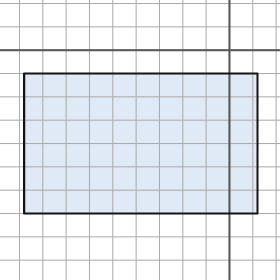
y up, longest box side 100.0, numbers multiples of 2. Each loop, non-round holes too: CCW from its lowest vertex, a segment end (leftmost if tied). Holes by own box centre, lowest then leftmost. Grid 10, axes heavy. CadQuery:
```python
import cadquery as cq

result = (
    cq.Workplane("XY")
    .moveTo(-88.0, -70.0)
    .lineTo(12.0, -70.0)
    .lineTo(12.0, -10.0)
    .lineTo(-88.0, -10.0)
    .close()
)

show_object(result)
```